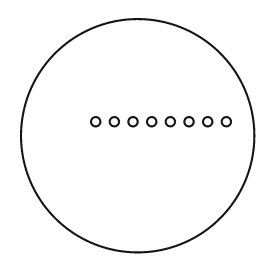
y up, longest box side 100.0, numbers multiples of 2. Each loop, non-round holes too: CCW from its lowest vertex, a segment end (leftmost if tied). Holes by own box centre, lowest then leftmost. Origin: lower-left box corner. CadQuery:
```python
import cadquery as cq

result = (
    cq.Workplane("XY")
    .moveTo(50.0, 50.0)
    .circle(50.0)
    .moveTo(32.0, 56.0)
    .circle(2.0)
    .moveTo(40.0, 56.0)
    .circle(2.0)
    .moveTo(48.0, 56.0)
    .circle(2.0)
    .moveTo(56.0, 56.0)
    .circle(2.0)
    .moveTo(64.0, 56.0)
    .circle(2.0)
    .moveTo(72.0, 56.0)
    .circle(2.0)
    .moveTo(80.0, 56.0)
    .circle(2.0)
    .moveTo(88.0, 56.0)
    .circle(2.0)
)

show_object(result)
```